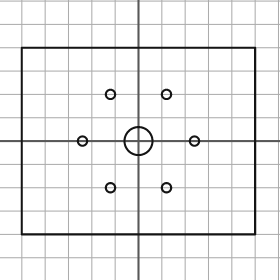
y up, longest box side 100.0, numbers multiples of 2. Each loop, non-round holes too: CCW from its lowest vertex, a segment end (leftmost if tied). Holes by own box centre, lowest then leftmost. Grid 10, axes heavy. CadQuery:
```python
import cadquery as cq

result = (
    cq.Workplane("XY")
    .moveTo(-50.0, -40.0)
    .lineTo(50.0, -40.0)
    .lineTo(50.0, 40.0)
    .lineTo(-50.0, 40.0)
    .close()
    .moveTo(-12.0, -20.0)
    .circle(2.0)
    .moveTo(12.0, -20.0)
    .circle(2.0)
    .moveTo(-24.0, 0.0)
    .circle(2.0)
    .moveTo(0.0, 0.0)
    .circle(6.0)
    .moveTo(24.0, 0.0)
    .circle(2.0)
    .moveTo(-12.0, 20.0)
    .circle(2.0)
    .moveTo(12.0, 20.0)
    .circle(2.0)
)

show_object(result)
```